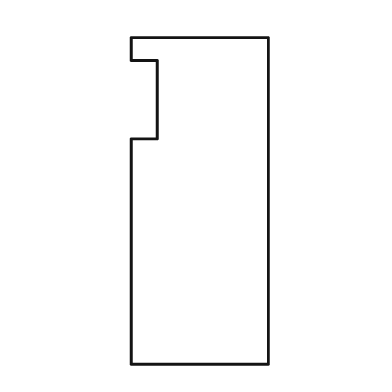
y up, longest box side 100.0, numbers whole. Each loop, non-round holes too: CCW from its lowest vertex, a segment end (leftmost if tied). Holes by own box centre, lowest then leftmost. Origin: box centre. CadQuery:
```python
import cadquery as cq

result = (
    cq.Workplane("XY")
    .moveTo(-21.0, -50.0)
    .lineTo(21.0, -50.0)
    .lineTo(21.0, 50.0)
    .lineTo(-21.0, 50.0)
    .lineTo(-21.0, 43.0)
    .lineTo(-13.0, 43.0)
    .lineTo(-13.0, 19.0)
    .lineTo(-21.0, 19.0)
    .close()
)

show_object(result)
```